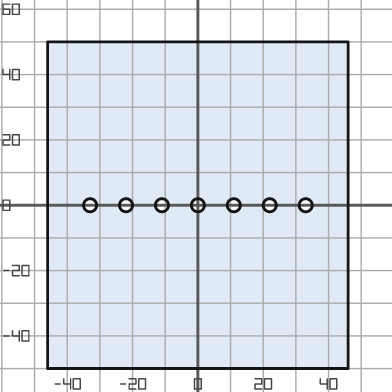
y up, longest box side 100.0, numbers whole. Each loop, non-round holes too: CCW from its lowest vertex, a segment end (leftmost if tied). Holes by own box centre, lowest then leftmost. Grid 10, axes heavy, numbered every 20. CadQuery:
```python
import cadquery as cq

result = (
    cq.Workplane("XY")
    .moveTo(-46.0, -50.0)
    .lineTo(46.0, -50.0)
    .lineTo(46.0, 50.0)
    .lineTo(-46.0, 50.0)
    .close()
    .moveTo(-33.0, 0.0)
    .circle(2.0)
    .moveTo(-22.0, 0.0)
    .circle(2.0)
    .moveTo(-11.0, 0.0)
    .circle(2.0)
    .moveTo(0.0, 0.0)
    .circle(2.0)
    .moveTo(11.0, 0.0)
    .circle(2.0)
    .moveTo(22.0, 0.0)
    .circle(2.0)
    .moveTo(33.0, 0.0)
    .circle(2.0)
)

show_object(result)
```